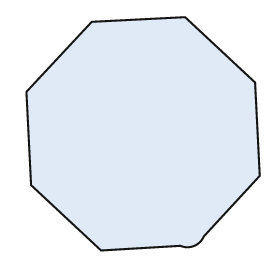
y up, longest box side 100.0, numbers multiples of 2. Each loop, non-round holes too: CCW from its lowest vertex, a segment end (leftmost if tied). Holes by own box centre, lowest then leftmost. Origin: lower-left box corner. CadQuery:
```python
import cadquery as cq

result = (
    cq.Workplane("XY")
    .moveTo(32.0, 0.0)
    .lineTo(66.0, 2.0)
    .threePointArc((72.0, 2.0), (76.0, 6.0))
    .lineTo(100.0, 32.0)
    .lineTo(98.0, 72.0)
    .lineTo(68.0, 100.0)
    .lineTo(28.0, 98.0)
    .lineTo(0.0, 68.0)
    .lineTo(2.0, 28.0)
    .close()
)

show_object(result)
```